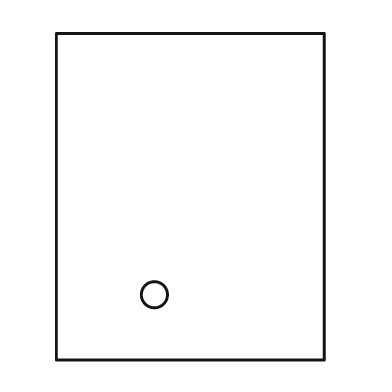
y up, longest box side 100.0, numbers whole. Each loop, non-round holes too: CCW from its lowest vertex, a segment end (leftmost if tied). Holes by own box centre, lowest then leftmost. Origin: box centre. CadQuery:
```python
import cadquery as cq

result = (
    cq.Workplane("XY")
    .moveTo(-41.0, -50.0)
    .lineTo(41.0, -50.0)
    .lineTo(41.0, 50.0)
    .lineTo(-41.0, 50.0)
    .close()
    .moveTo(-11.0, -30.0)
    .circle(4.0)
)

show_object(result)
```